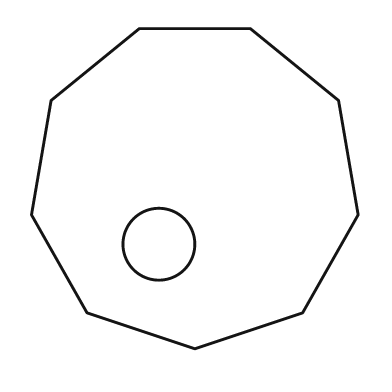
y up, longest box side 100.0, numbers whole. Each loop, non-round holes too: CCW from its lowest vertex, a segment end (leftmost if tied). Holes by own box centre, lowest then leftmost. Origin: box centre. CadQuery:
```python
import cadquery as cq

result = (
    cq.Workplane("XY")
    .moveTo(0.0, -49.0)
    .lineTo(33.0, -38.0)
    .lineTo(50.0, -8.0)
    .lineTo(44.0, 27.0)
    .lineTo(17.0, 49.0)
    .lineTo(-17.0, 49.0)
    .lineTo(-44.0, 27.0)
    .lineTo(-50.0, -8.0)
    .lineTo(-33.0, -38.0)
    .close()
    .moveTo(-11.0, -17.0)
    .circle(11.0)
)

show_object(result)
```